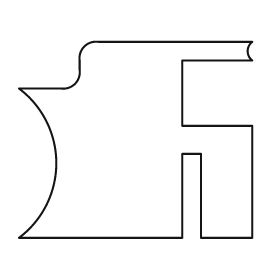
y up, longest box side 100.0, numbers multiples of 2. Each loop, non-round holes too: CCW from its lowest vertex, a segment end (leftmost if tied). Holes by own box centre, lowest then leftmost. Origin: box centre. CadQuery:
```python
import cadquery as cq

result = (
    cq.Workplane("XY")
    .moveTo(-50.0, -42.0)
    .lineTo(20.0, -42.0)
    .lineTo(20.0, -6.0)
    .lineTo(28.0, -6.0)
    .lineTo(28.0, -42.0)
    .lineTo(50.0, -42.0)
    .lineTo(50.0, 6.0)
    .lineTo(20.0, 6.0)
    .lineTo(20.0, 34.0)
    .lineTo(50.0, 34.0)
    .threePointArc((48.0, 38.0), (50.0, 42.0))
    .lineTo(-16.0, 42.0)
    .threePointArc((-22.0, 40.0), (-24.0, 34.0))
    .lineTo(-24.0, 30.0)
    .threePointArc((-26.0, 24.0), (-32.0, 22.0))
    .lineTo(-50.0, 22.0)
    .threePointArc((-34.0, -10.0), (-50.0, -42.0))
    .close()
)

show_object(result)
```